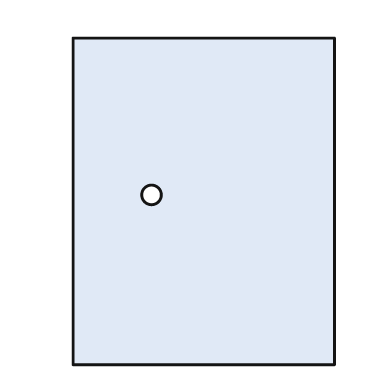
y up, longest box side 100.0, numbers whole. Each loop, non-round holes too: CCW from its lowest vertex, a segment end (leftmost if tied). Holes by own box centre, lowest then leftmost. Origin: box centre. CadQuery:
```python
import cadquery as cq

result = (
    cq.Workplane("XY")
    .moveTo(-40.0, -50.0)
    .lineTo(40.0, -50.0)
    .lineTo(40.0, 50.0)
    .lineTo(-40.0, 50.0)
    .close()
    .moveTo(-16.0, 2.0)
    .circle(3.0)
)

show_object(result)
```